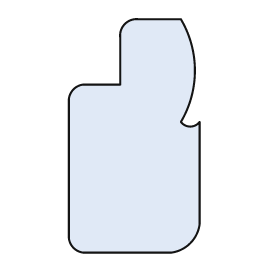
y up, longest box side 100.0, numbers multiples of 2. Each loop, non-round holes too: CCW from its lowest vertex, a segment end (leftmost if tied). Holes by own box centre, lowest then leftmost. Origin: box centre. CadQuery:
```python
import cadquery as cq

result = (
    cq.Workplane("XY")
    .moveTo(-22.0, -50.0)
    .lineTo(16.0, -50.0)
    .threePointArc((24.0, -46.0), (28.0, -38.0))
    .lineTo(28.0, 6.0)
    .threePointArc((24.0, 4.0), (20.0, 6.0))
    .threePointArc((26.0, 28.0), (20.0, 50.0))
    .lineTo(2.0, 50.0)
    .threePointArc((-4.0, 48.0), (-6.0, 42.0))
    .lineTo(-6.0, 22.0)
    .lineTo(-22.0, 22.0)
    .threePointArc((-26.0, 20.0), (-28.0, 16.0))
    .lineTo(-28.0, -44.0)
    .threePointArc((-26.0, -48.0), (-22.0, -50.0))
    .close()
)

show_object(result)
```